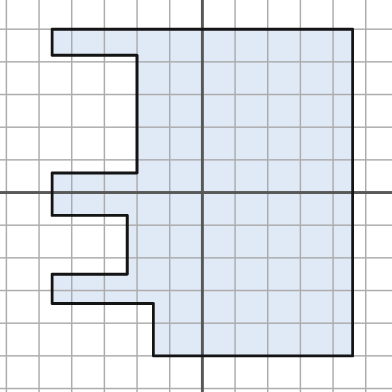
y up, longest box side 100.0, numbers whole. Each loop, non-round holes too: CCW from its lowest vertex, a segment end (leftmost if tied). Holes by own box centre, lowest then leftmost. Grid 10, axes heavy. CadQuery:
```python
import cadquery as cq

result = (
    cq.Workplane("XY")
    .moveTo(-15.0, -50.0)
    .lineTo(46.0, -50.0)
    .lineTo(46.0, 50.0)
    .lineTo(-46.0, 50.0)
    .lineTo(-46.0, 42.0)
    .lineTo(-20.0, 42.0)
    .lineTo(-20.0, 6.0)
    .lineTo(-46.0, 6.0)
    .lineTo(-46.0, -7.0)
    .lineTo(-23.0, -7.0)
    .lineTo(-23.0, -25.0)
    .lineTo(-46.0, -25.0)
    .lineTo(-46.0, -34.0)
    .lineTo(-15.0, -34.0)
    .close()
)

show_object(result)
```